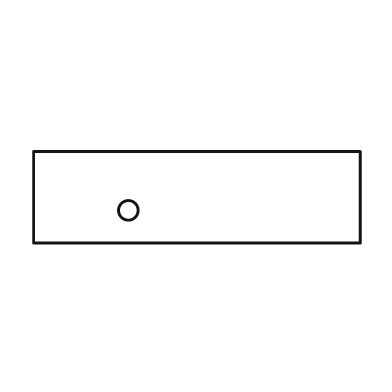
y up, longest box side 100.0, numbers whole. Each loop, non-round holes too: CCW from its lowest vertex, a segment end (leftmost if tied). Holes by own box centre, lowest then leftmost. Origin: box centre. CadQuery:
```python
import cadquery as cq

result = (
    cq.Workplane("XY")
    .moveTo(-50.0, -14.0)
    .lineTo(50.0, -14.0)
    .lineTo(50.0, 14.0)
    .lineTo(-50.0, 14.0)
    .close()
    .moveTo(-21.0, -4.0)
    .circle(3.0)
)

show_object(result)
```